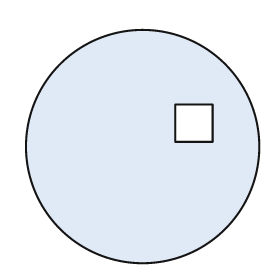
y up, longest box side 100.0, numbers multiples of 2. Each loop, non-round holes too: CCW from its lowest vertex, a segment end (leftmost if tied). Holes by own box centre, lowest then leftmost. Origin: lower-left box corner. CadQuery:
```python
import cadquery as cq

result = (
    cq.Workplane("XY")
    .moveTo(50.0, 50.0)
    .circle(50.0)
    .moveTo(64.0, 52.0)
    .lineTo(80.0, 52.0)
    .lineTo(80.0, 68.0)
    .lineTo(64.0, 68.0)
    .close()
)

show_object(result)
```